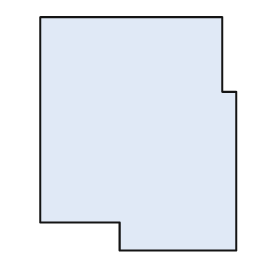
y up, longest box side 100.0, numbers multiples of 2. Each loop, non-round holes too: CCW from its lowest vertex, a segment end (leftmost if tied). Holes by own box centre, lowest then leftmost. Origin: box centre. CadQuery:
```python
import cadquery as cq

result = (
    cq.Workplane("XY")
    .moveTo(-8.0, -50.0)
    .lineTo(42.0, -50.0)
    .lineTo(42.0, 18.0)
    .lineTo(36.0, 18.0)
    .lineTo(36.0, 50.0)
    .lineTo(-42.0, 50.0)
    .lineTo(-42.0, -38.0)
    .lineTo(-8.0, -38.0)
    .close()
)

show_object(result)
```